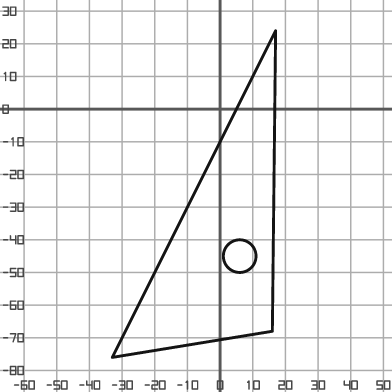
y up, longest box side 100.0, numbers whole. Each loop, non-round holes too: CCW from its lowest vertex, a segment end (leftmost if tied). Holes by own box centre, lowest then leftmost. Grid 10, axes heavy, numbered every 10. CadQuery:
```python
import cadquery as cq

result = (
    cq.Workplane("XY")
    .moveTo(-33.0, -76.0)
    .lineTo(16.0, -68.0)
    .lineTo(17.0, 24.0)
    .close()
    .moveTo(6.0, -45.0)
    .circle(5.0)
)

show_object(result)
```